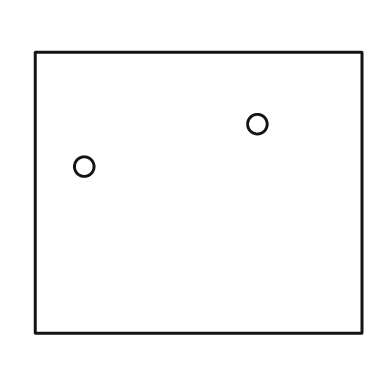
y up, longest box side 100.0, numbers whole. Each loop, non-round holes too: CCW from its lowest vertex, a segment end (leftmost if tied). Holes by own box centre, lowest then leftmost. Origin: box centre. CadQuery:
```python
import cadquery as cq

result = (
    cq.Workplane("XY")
    .moveTo(-50.0, -43.0)
    .lineTo(50.0, -43.0)
    .lineTo(50.0, 43.0)
    .lineTo(-50.0, 43.0)
    .close()
    .moveTo(-35.0, 8.0)
    .circle(3.0)
    .moveTo(18.0, 21.0)
    .circle(3.0)
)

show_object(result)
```